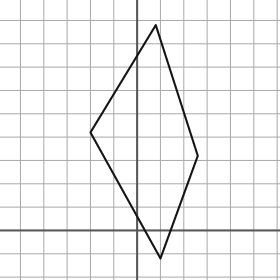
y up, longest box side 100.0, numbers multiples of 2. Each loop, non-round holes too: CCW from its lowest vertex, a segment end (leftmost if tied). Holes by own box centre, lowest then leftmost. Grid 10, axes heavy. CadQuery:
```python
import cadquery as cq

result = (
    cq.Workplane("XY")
    .moveTo(10.0, -12.0)
    .lineTo(26.0, 32.0)
    .lineTo(8.0, 88.0)
    .lineTo(-20.0, 42.0)
    .close()
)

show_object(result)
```